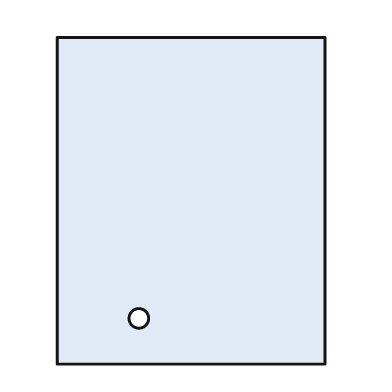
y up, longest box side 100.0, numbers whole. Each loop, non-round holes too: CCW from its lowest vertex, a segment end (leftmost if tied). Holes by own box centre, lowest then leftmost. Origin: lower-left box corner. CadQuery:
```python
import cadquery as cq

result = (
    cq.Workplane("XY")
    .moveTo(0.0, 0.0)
    .lineTo(82.0, 0.0)
    .lineTo(82.0, 100.0)
    .lineTo(0.0, 100.0)
    .close()
    .moveTo(25.0, 14.0)
    .circle(3.0)
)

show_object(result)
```